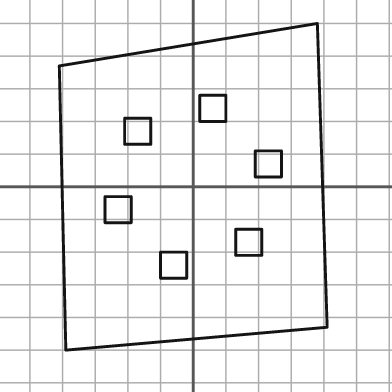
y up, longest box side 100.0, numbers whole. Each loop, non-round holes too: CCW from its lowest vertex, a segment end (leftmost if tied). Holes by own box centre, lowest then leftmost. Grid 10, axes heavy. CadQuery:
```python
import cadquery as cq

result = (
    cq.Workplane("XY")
    .moveTo(-39.0, -50.0)
    .lineTo(41.0, -43.0)
    .lineTo(38.0, 50.0)
    .lineTo(-41.0, 37.0)
    .close()
    .moveTo(-10.0, -28.0)
    .lineTo(-2.0, -28.0)
    .lineTo(-2.0, -20.0)
    .lineTo(-10.0, -20.0)
    .close()
    .moveTo(13.0, -21.0)
    .lineTo(21.0, -21.0)
    .lineTo(21.0, -13.0)
    .lineTo(13.0, -13.0)
    .close()
    .moveTo(-27.0, -11.0)
    .lineTo(-19.0, -11.0)
    .lineTo(-19.0, -3.0)
    .lineTo(-27.0, -3.0)
    .close()
    .moveTo(19.0, 3.0)
    .lineTo(27.0, 3.0)
    .lineTo(27.0, 11.0)
    .lineTo(19.0, 11.0)
    .close()
    .moveTo(-21.0, 13.0)
    .lineTo(-13.0, 13.0)
    .lineTo(-13.0, 21.0)
    .lineTo(-21.0, 21.0)
    .close()
    .moveTo(2.0, 20.0)
    .lineTo(10.0, 20.0)
    .lineTo(10.0, 28.0)
    .lineTo(2.0, 28.0)
    .close()
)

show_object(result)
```